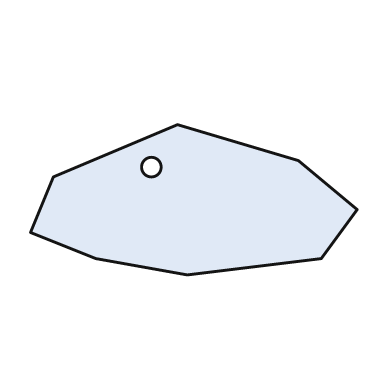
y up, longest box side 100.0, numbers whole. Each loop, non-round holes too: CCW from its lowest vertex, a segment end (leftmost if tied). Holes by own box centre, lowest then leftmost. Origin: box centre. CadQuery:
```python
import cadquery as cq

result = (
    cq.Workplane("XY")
    .moveTo(-2.0, -23.0)
    .lineTo(39.0, -18.0)
    .lineTo(50.0, -3.0)
    .lineTo(32.0, 12.0)
    .lineTo(-5.0, 23.0)
    .lineTo(-43.0, 7.0)
    .lineTo(-50.0, -10.0)
    .lineTo(-30.0, -18.0)
    .close()
    .moveTo(-13.0, 10.0)
    .circle(3.0)
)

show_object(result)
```